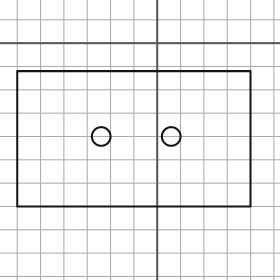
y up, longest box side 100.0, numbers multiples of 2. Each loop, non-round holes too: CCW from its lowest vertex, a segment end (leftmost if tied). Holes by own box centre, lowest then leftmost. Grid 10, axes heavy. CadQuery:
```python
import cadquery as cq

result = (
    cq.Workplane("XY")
    .moveTo(-60.0, -70.0)
    .lineTo(40.0, -70.0)
    .lineTo(40.0, -12.0)
    .lineTo(-60.0, -12.0)
    .close()
    .moveTo(-24.0, -40.0)
    .circle(4.0)
    .moveTo(6.0, -40.0)
    .circle(4.0)
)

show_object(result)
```